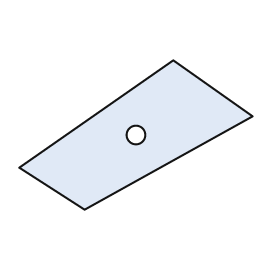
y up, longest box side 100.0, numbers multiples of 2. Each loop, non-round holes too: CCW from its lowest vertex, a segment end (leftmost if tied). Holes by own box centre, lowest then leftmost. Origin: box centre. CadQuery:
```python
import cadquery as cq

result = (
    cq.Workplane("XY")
    .moveTo(-22.0, -32.0)
    .lineTo(50.0, 8.0)
    .lineTo(16.0, 32.0)
    .lineTo(-50.0, -14.0)
    .close()
    .moveTo(0.0, 0.0)
    .circle(4.0)
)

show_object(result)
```